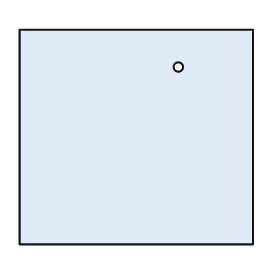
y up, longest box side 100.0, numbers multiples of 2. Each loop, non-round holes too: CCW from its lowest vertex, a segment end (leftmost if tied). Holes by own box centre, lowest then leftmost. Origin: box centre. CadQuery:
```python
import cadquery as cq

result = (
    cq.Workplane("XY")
    .moveTo(-50.0, -46.0)
    .lineTo(50.0, -46.0)
    .lineTo(50.0, 46.0)
    .lineTo(-50.0, 46.0)
    .close()
    .moveTo(18.0, 30.0)
    .circle(2.0)
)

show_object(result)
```